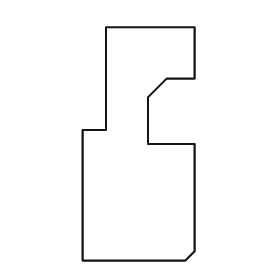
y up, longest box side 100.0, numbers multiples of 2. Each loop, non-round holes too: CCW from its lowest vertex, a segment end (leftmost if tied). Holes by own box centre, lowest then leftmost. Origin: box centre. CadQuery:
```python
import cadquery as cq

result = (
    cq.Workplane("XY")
    .moveTo(-24.0, -50.0)
    .lineTo(20.0, -50.0)
    .lineTo(24.0, -46.0)
    .lineTo(24.0, 0.0)
    .lineTo(4.0, 0.0)
    .lineTo(4.0, 20.0)
    .lineTo(12.0, 28.0)
    .lineTo(24.0, 28.0)
    .lineTo(24.0, 50.0)
    .lineTo(-14.0, 50.0)
    .lineTo(-14.0, 6.0)
    .lineTo(-24.0, 6.0)
    .close()
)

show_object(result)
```